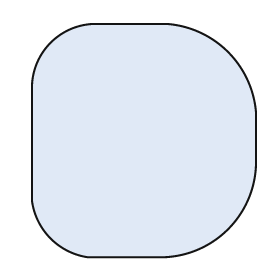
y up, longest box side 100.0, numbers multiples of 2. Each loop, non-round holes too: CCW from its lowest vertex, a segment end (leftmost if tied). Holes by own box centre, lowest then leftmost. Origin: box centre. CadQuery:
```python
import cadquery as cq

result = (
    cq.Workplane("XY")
    .moveTo(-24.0, -50.0)
    .lineTo(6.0, -50.0)
    .threePointArc((36.0, -38.0), (48.0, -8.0))
    .lineTo(48.0, 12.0)
    .threePointArc((36.0, 38.0), (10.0, 50.0))
    .lineTo(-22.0, 50.0)
    .threePointArc((-40.0, 42.0), (-48.0, 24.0))
    .lineTo(-48.0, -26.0)
    .threePointArc((-40.0, -42.0), (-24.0, -50.0))
    .close()
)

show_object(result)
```